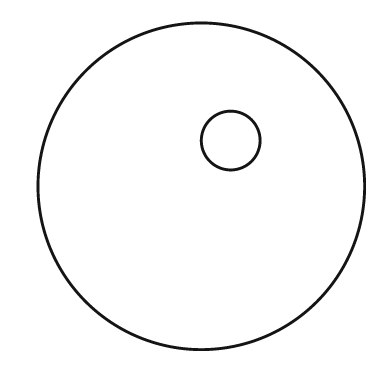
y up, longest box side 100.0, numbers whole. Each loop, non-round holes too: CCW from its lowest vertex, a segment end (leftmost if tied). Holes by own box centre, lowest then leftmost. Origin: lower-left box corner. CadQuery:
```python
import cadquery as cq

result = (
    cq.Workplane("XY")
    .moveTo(50.0, 50.0)
    .circle(50.0)
    .moveTo(59.0, 64.0)
    .circle(9.0)
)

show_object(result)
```